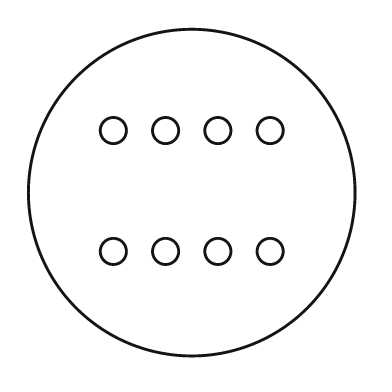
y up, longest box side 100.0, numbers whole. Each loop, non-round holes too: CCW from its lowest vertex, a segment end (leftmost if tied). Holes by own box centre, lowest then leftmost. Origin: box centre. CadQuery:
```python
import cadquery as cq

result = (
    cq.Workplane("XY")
    .moveTo(0.0, 0.0)
    .circle(50.0)
    .moveTo(-24.0, -18.0)
    .circle(4.0)
    .moveTo(-8.0, -18.0)
    .circle(4.0)
    .moveTo(8.0, -18.0)
    .circle(4.0)
    .moveTo(24.0, -18.0)
    .circle(4.0)
    .moveTo(-24.0, 19.0)
    .circle(4.0)
    .moveTo(-8.0, 19.0)
    .circle(4.0)
    .moveTo(8.0, 19.0)
    .circle(4.0)
    .moveTo(24.0, 19.0)
    .circle(4.0)
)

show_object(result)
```